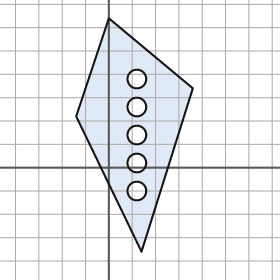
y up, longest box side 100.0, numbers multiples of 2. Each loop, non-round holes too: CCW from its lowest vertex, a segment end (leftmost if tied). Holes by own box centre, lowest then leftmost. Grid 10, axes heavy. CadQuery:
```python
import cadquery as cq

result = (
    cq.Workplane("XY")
    .moveTo(14.0, -36.0)
    .lineTo(36.0, 34.0)
    .lineTo(0.0, 64.0)
    .lineTo(-14.0, 22.0)
    .close()
    .moveTo(12.0, -10.0)
    .circle(4.0)
    .moveTo(12.0, 2.0)
    .circle(4.0)
    .moveTo(12.0, 14.0)
    .circle(4.0)
    .moveTo(12.0, 26.0)
    .circle(4.0)
    .moveTo(12.0, 38.0)
    .circle(4.0)
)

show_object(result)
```